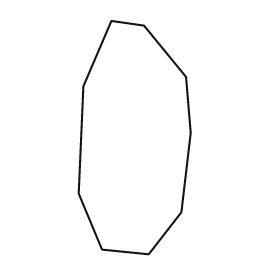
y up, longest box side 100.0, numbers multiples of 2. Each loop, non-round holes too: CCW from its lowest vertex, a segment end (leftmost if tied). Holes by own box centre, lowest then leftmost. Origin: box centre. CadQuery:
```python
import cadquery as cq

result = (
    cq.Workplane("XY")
    .moveTo(6.0, -50.0)
    .lineTo(20.0, -32.0)
    .lineTo(24.0, 2.0)
    .lineTo(22.0, 26.0)
    .lineTo(4.0, 48.0)
    .lineTo(-10.0, 50.0)
    .lineTo(-22.0, 22.0)
    .lineTo(-24.0, -24.0)
    .lineTo(-14.0, -48.0)
    .close()
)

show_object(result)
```